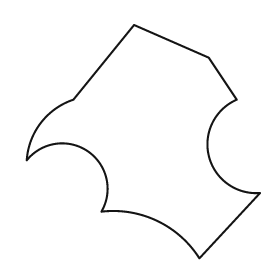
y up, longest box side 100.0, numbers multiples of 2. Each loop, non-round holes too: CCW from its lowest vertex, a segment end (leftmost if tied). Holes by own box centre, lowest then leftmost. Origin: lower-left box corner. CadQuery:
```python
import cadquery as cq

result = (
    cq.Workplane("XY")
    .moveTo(74.0, 0.0)
    .lineTo(100.0, 28.0)
    .threePointArc((78.0, 44.0), (90.0, 68.0))
    .lineTo(78.0, 86.0)
    .lineTo(46.0, 100.0)
    .lineTo(20.0, 68.0)
    .threePointArc((6.0, 58.0), (0.0, 42.0))
    .threePointArc((26.0, 46.0), (32.0, 20.0))
    .threePointArc((56.0, 16.0), (74.0, 0.0))
    .close()
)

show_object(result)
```